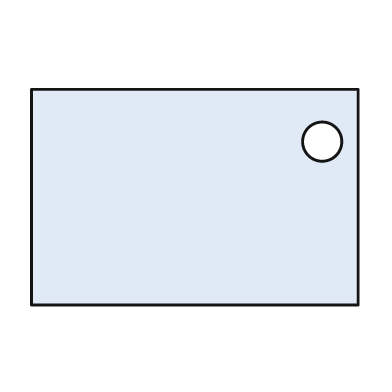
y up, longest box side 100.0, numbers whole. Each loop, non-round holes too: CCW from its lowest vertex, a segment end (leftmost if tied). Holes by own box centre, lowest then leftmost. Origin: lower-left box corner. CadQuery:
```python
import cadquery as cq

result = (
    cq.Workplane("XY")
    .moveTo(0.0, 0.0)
    .lineTo(100.0, 0.0)
    .lineTo(100.0, 66.0)
    .lineTo(0.0, 66.0)
    .close()
    .moveTo(89.0, 50.0)
    .circle(6.0)
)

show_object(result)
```